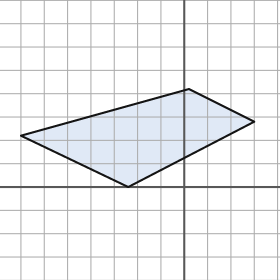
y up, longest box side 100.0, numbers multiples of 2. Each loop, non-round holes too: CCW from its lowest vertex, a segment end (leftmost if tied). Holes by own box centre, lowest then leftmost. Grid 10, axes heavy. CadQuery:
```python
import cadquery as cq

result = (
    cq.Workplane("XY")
    .moveTo(-24.0, 0.0)
    .lineTo(30.0, 28.0)
    .lineTo(2.0, 42.0)
    .lineTo(-70.0, 22.0)
    .close()
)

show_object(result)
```